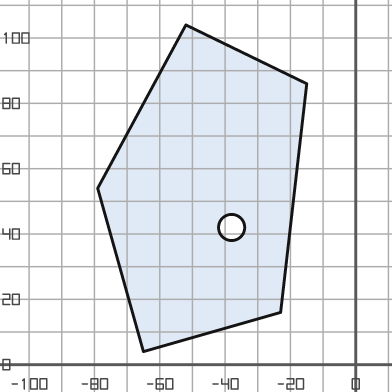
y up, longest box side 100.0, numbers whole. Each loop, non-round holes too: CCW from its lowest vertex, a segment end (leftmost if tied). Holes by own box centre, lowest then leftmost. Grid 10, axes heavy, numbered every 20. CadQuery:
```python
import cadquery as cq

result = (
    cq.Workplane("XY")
    .moveTo(-65.0, 4.0)
    .lineTo(-23.0, 16.0)
    .lineTo(-15.0, 86.0)
    .lineTo(-52.0, 104.0)
    .lineTo(-79.0, 54.0)
    .close()
    .moveTo(-38.0, 42.0)
    .circle(4.0)
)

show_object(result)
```